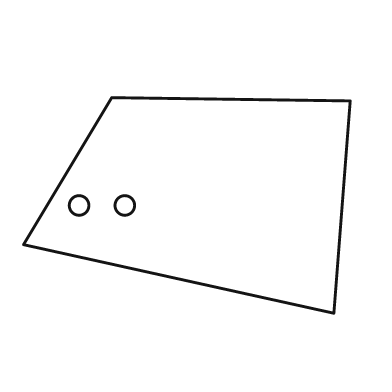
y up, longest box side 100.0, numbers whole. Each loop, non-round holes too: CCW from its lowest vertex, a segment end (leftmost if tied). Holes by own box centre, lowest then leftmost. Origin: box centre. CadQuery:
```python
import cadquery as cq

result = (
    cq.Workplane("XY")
    .moveTo(45.0, -33.0)
    .lineTo(50.0, 32.0)
    .lineTo(-23.0, 33.0)
    .lineTo(-50.0, -12.0)
    .close()
    .moveTo(-33.0, 0.0)
    .circle(3.0)
    .moveTo(-19.0, 0.0)
    .circle(3.0)
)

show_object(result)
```